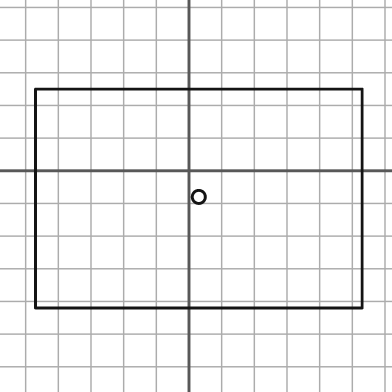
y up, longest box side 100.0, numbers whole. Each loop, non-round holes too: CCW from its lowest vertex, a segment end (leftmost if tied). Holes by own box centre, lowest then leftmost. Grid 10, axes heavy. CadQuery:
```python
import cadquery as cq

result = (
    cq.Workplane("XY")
    .moveTo(-47.0, -42.0)
    .lineTo(53.0, -42.0)
    .lineTo(53.0, 25.0)
    .lineTo(-47.0, 25.0)
    .close()
    .moveTo(3.0, -8.0)
    .circle(2.0)
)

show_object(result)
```